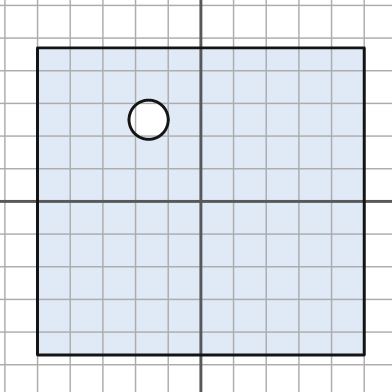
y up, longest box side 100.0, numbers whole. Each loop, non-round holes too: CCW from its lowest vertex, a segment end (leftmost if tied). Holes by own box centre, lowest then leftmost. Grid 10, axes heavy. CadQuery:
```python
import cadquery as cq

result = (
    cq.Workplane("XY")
    .moveTo(-50.0, -47.0)
    .lineTo(50.0, -47.0)
    .lineTo(50.0, 47.0)
    .lineTo(-50.0, 47.0)
    .close()
    .moveTo(-16.0, 25.0)
    .circle(6.0)
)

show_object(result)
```